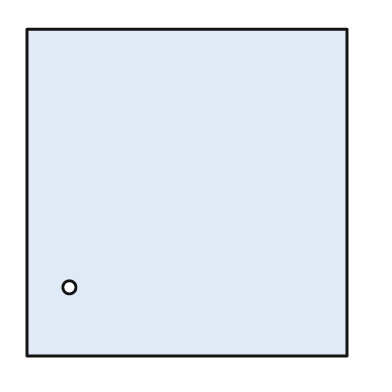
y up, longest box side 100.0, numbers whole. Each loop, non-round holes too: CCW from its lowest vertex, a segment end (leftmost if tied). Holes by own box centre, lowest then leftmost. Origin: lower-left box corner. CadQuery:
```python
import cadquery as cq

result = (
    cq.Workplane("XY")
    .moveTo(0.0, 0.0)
    .lineTo(98.0, 0.0)
    .lineTo(98.0, 100.0)
    .lineTo(0.0, 100.0)
    .close()
    .moveTo(13.0, 21.0)
    .circle(2.0)
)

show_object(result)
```